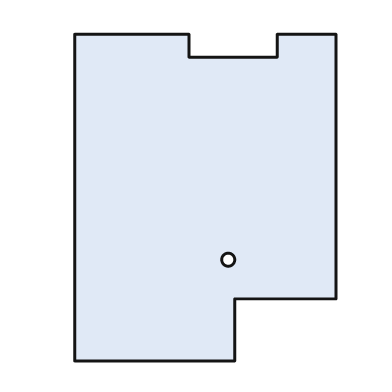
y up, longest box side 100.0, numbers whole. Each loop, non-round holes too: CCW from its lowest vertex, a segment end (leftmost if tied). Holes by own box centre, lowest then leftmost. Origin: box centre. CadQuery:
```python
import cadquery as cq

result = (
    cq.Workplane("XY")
    .moveTo(-40.0, -50.0)
    .lineTo(9.0, -50.0)
    .lineTo(9.0, -31.0)
    .lineTo(40.0, -31.0)
    .lineTo(40.0, 50.0)
    .lineTo(22.0, 50.0)
    .lineTo(22.0, 43.0)
    .lineTo(-5.0, 43.0)
    .lineTo(-5.0, 50.0)
    .lineTo(-40.0, 50.0)
    .close()
    .moveTo(7.0, -19.0)
    .circle(2.0)
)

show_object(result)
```